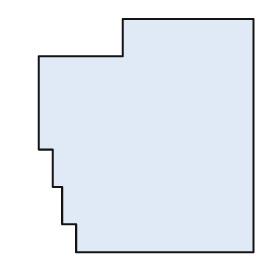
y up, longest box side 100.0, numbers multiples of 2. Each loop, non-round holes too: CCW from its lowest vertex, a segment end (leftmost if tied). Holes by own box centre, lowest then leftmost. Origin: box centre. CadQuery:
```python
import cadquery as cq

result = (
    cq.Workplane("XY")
    .moveTo(-30.0, -50.0)
    .lineTo(46.0, -50.0)
    .lineTo(46.0, 50.0)
    .lineTo(-10.0, 50.0)
    .lineTo(-10.0, 34.0)
    .lineTo(-46.0, 34.0)
    .lineTo(-46.0, -6.0)
    .lineTo(-40.0, -6.0)
    .lineTo(-40.0, -22.0)
    .lineTo(-36.0, -22.0)
    .lineTo(-36.0, -38.0)
    .lineTo(-30.0, -38.0)
    .close()
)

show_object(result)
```